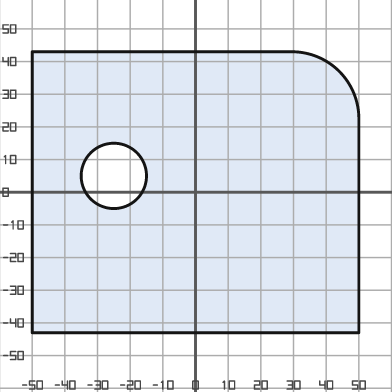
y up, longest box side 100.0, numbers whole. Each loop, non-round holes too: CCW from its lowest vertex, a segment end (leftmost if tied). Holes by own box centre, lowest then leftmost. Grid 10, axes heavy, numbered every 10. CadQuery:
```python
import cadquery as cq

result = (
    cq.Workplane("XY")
    .moveTo(-50.0, -43.0)
    .lineTo(50.0, -43.0)
    .lineTo(50.0, 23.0)
    .threePointArc((44.0, 37.0), (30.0, 43.0))
    .lineTo(-50.0, 43.0)
    .close()
    .moveTo(-25.0, 5.0)
    .circle(10.0)
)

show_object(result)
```